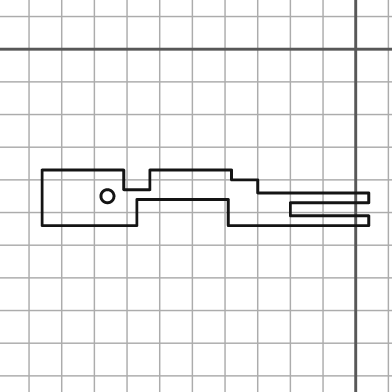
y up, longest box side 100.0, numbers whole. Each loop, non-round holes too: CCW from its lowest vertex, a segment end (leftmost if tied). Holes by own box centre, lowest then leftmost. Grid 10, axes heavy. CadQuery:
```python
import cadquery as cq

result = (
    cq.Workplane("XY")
    .moveTo(-96.0, -54.0)
    .lineTo(-67.0, -54.0)
    .lineTo(-67.0, -46.0)
    .lineTo(-39.0, -46.0)
    .lineTo(-39.0, -54.0)
    .lineTo(4.0, -54.0)
    .lineTo(4.0, -51.0)
    .lineTo(-20.0, -51.0)
    .lineTo(-20.0, -47.0)
    .lineTo(4.0, -47.0)
    .lineTo(4.0, -44.0)
    .lineTo(-30.0, -44.0)
    .lineTo(-30.0, -40.0)
    .lineTo(-38.0, -40.0)
    .lineTo(-38.0, -37.0)
    .lineTo(-63.0, -37.0)
    .lineTo(-63.0, -43.0)
    .lineTo(-71.0, -43.0)
    .lineTo(-71.0, -37.0)
    .lineTo(-96.0, -37.0)
    .close()
    .moveTo(-76.0, -45.0)
    .circle(2.0)
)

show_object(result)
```